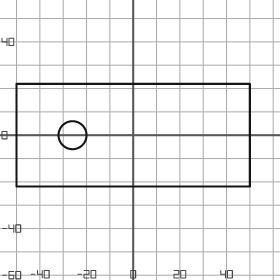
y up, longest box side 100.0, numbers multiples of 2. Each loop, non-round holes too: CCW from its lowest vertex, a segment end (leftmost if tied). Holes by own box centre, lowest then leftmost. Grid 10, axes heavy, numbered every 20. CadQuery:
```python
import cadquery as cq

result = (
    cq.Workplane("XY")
    .moveTo(-50.0, -22.0)
    .lineTo(50.0, -22.0)
    .lineTo(50.0, 22.0)
    .lineTo(-50.0, 22.0)
    .close()
    .moveTo(-26.0, 0.0)
    .circle(6.0)
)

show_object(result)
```